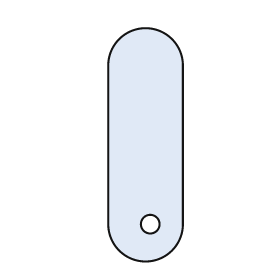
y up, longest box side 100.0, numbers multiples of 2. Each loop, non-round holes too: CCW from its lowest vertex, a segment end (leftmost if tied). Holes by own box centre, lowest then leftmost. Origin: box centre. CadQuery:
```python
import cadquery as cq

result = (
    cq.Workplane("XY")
    .moveTo(-16.0, -34.0)
    .threePointArc((0.0, -50.0), (16.0, -34.0))
    .lineTo(16.0, 34.0)
    .threePointArc((0.0, 50.0), (-16.0, 34.0))
    .close()
    .moveTo(2.0, -34.0)
    .circle(4.0)
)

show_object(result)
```